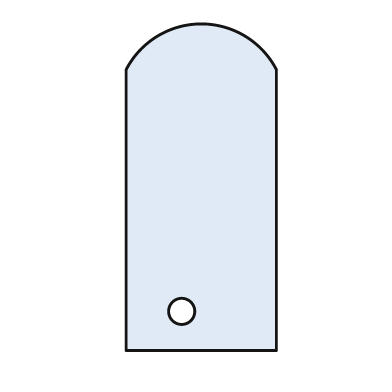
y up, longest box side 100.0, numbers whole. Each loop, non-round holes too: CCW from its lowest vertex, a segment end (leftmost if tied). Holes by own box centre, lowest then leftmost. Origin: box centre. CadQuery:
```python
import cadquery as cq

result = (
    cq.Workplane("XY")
    .moveTo(-23.0, -50.0)
    .lineTo(23.0, -50.0)
    .lineTo(23.0, 36.0)
    .threePointArc((0.0, 50.0), (-23.0, 36.0))
    .close()
    .moveTo(-6.0, -38.0)
    .circle(4.0)
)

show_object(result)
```